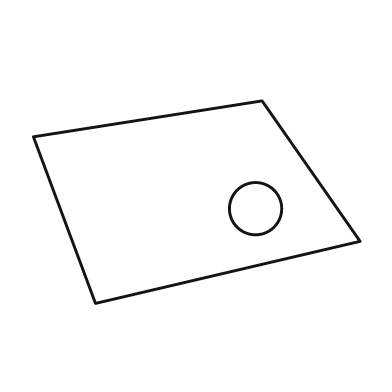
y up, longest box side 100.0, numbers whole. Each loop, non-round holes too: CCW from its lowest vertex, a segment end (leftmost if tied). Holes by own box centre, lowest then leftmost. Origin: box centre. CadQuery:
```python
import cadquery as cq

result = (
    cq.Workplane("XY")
    .moveTo(-31.0, -31.0)
    .lineTo(50.0, -12.0)
    .lineTo(20.0, 31.0)
    .lineTo(-50.0, 20.0)
    .close()
    .moveTo(18.0, -2.0)
    .circle(8.0)
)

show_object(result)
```